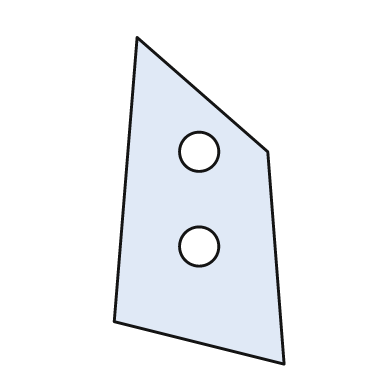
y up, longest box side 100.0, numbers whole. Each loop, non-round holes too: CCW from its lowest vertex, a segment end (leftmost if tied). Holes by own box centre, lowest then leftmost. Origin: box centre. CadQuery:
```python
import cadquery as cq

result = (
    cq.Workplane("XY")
    .moveTo(26.0, -50.0)
    .lineTo(21.0, 15.0)
    .lineTo(-19.0, 50.0)
    .lineTo(-26.0, -37.0)
    .close()
    .moveTo(0.0, -14.0)
    .circle(6.0)
    .moveTo(0.0, 15.0)
    .circle(6.0)
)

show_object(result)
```